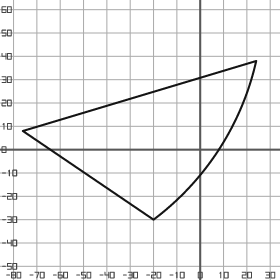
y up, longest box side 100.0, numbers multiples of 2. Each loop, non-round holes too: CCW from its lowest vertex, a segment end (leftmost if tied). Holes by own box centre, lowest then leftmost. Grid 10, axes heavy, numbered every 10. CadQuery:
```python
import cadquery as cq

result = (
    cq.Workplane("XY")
    .moveTo(-20.0, -30.0)
    .threePointArc((8.0, 0.0), (24.0, 38.0))
    .lineTo(-76.0, 8.0)
    .close()
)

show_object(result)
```